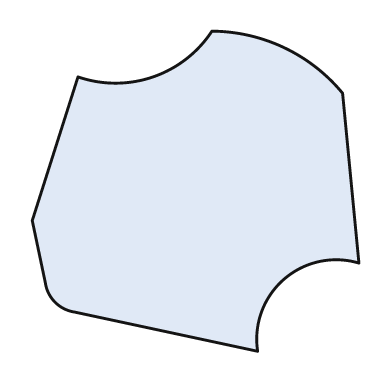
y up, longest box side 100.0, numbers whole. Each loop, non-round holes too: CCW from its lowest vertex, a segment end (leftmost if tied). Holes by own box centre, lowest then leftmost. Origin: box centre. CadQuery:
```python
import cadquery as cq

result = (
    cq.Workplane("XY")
    .moveTo(19.0, -49.0)
    .threePointArc((27.0, -27.0), (50.0, -22.0))
    .lineTo(45.0, 30.0)
    .threePointArc((27.0, 44.0), (5.0, 49.0))
    .threePointArc((-13.0, 35.0), (-36.0, 35.0))
    .lineTo(-50.0, -9.0)
    .lineTo(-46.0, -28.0)
    .threePointArc((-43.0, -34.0), (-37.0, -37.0))
    .close()
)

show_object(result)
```